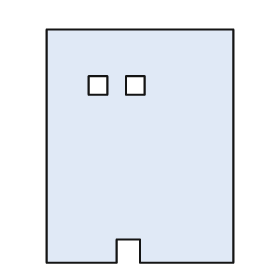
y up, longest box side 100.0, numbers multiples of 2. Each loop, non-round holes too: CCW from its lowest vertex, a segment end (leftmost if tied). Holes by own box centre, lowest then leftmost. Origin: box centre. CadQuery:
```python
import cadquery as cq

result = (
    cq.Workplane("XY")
    .moveTo(-40.0, -50.0)
    .lineTo(-10.0, -50.0)
    .lineTo(-10.0, -40.0)
    .lineTo(0.0, -40.0)
    .lineTo(0.0, -50.0)
    .lineTo(40.0, -50.0)
    .lineTo(40.0, 50.0)
    .lineTo(-40.0, 50.0)
    .close()
    .moveTo(-22.0, 22.0)
    .lineTo(-14.0, 22.0)
    .lineTo(-14.0, 30.0)
    .lineTo(-22.0, 30.0)
    .close()
    .moveTo(-6.0, 22.0)
    .lineTo(2.0, 22.0)
    .lineTo(2.0, 30.0)
    .lineTo(-6.0, 30.0)
    .close()
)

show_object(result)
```